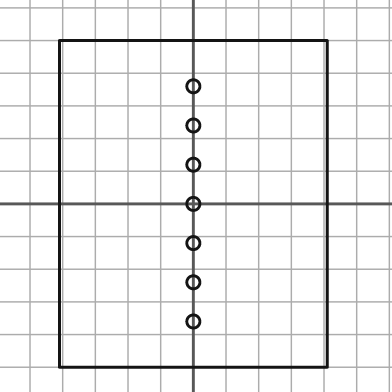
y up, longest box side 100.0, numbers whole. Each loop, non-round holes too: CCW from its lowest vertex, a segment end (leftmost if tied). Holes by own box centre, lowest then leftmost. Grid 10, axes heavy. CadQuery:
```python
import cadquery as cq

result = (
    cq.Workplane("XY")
    .moveTo(-41.0, -50.0)
    .lineTo(41.0, -50.0)
    .lineTo(41.0, 50.0)
    .lineTo(-41.0, 50.0)
    .close()
    .moveTo(0.0, -36.0)
    .circle(2.0)
    .moveTo(0.0, -24.0)
    .circle(2.0)
    .moveTo(0.0, -12.0)
    .circle(2.0)
    .moveTo(0.0, 0.0)
    .circle(2.0)
    .moveTo(0.0, 12.0)
    .circle(2.0)
    .moveTo(0.0, 24.0)
    .circle(2.0)
    .moveTo(0.0, 36.0)
    .circle(2.0)
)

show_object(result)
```